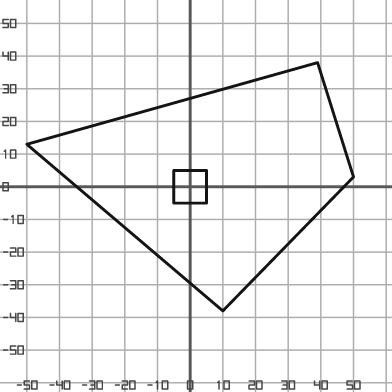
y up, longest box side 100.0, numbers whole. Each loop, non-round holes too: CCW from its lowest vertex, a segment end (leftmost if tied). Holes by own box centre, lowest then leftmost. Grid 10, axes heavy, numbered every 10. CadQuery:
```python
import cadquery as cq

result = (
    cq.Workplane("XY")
    .moveTo(10.0, -38.0)
    .lineTo(50.0, 3.0)
    .lineTo(39.0, 38.0)
    .lineTo(-50.0, 13.0)
    .close()
    .moveTo(-5.0, -5.0)
    .lineTo(5.0, -5.0)
    .lineTo(5.0, 5.0)
    .lineTo(-5.0, 5.0)
    .close()
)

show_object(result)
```